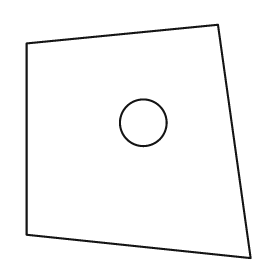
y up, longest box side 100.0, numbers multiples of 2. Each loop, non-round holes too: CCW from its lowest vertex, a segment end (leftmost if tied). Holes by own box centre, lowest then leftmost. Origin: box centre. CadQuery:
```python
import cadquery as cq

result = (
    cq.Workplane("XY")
    .moveTo(48.0, -50.0)
    .lineTo(34.0, 50.0)
    .lineTo(-48.0, 42.0)
    .lineTo(-48.0, -40.0)
    .close()
    .moveTo(2.0, 8.0)
    .circle(10.0)
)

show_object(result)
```